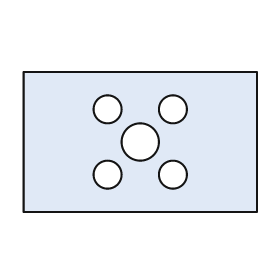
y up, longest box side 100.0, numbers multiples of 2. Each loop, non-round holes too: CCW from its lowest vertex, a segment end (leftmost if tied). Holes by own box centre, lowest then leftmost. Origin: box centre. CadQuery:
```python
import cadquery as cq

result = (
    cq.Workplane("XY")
    .moveTo(-50.0, -30.0)
    .lineTo(50.0, -30.0)
    .lineTo(50.0, 30.0)
    .lineTo(-50.0, 30.0)
    .close()
    .moveTo(-14.0, -14.0)
    .circle(6.0)
    .moveTo(14.0, -14.0)
    .circle(6.0)
    .moveTo(0.0, 0.0)
    .circle(8.0)
    .moveTo(-14.0, 14.0)
    .circle(6.0)
    .moveTo(14.0, 14.0)
    .circle(6.0)
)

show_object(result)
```